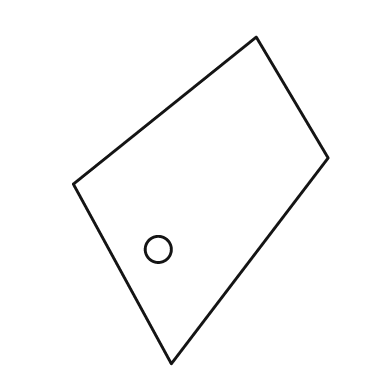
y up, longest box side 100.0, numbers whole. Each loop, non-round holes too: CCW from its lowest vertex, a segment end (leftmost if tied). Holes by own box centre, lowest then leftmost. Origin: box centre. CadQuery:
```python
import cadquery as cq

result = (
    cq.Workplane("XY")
    .moveTo(-9.0, -50.0)
    .lineTo(39.0, 13.0)
    .lineTo(17.0, 50.0)
    .lineTo(-39.0, 5.0)
    .close()
    .moveTo(-13.0, -15.0)
    .circle(4.0)
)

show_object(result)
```